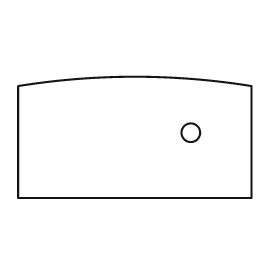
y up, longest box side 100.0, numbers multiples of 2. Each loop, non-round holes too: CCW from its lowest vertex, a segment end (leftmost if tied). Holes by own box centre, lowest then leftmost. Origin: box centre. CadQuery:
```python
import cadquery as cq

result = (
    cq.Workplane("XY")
    .moveTo(-50.0, -26.0)
    .lineTo(50.0, -26.0)
    .lineTo(50.0, 22.0)
    .threePointArc((0.0, 26.0), (-50.0, 22.0))
    .close()
    .moveTo(24.0, 2.0)
    .circle(4.0)
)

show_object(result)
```